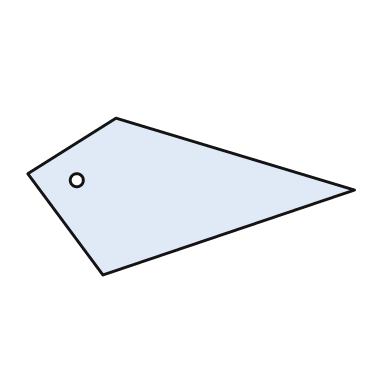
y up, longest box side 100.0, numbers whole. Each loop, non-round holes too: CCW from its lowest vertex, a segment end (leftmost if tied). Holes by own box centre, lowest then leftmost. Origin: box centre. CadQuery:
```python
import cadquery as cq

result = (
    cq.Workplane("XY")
    .moveTo(-27.0, -24.0)
    .lineTo(50.0, 2.0)
    .lineTo(-23.0, 24.0)
    .lineTo(-50.0, 7.0)
    .close()
    .moveTo(-35.0, 5.0)
    .circle(2.0)
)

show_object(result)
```